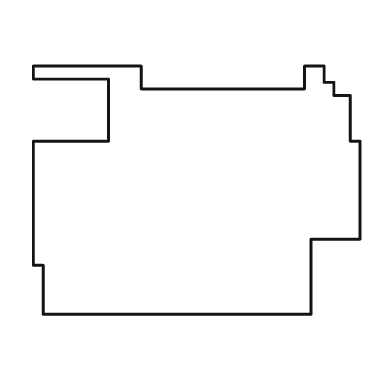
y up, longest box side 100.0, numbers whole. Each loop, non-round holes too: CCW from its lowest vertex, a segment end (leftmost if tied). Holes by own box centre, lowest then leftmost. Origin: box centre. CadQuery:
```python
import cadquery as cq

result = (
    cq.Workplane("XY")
    .moveTo(-47.0, -38.0)
    .lineTo(35.0, -38.0)
    .lineTo(35.0, -15.0)
    .lineTo(50.0, -15.0)
    .lineTo(50.0, 15.0)
    .lineTo(47.0, 15.0)
    .lineTo(47.0, 29.0)
    .lineTo(42.0, 29.0)
    .lineTo(42.0, 33.0)
    .lineTo(39.0, 33.0)
    .lineTo(39.0, 38.0)
    .lineTo(33.0, 38.0)
    .lineTo(33.0, 31.0)
    .lineTo(-17.0, 31.0)
    .lineTo(-17.0, 38.0)
    .lineTo(-50.0, 38.0)
    .lineTo(-50.0, 34.0)
    .lineTo(-27.0, 34.0)
    .lineTo(-27.0, 15.0)
    .lineTo(-50.0, 15.0)
    .lineTo(-50.0, -23.0)
    .lineTo(-47.0, -23.0)
    .close()
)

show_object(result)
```